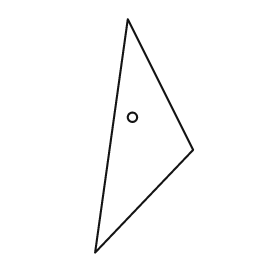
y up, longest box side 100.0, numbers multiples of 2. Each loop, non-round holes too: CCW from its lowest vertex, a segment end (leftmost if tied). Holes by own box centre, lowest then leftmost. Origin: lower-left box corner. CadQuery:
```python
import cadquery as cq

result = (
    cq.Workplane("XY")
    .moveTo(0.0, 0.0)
    .lineTo(42.0, 44.0)
    .lineTo(14.0, 100.0)
    .close()
    .moveTo(16.0, 58.0)
    .circle(2.0)
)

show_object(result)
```